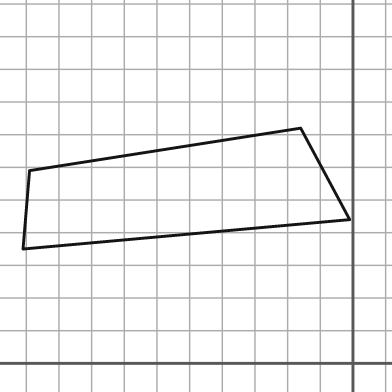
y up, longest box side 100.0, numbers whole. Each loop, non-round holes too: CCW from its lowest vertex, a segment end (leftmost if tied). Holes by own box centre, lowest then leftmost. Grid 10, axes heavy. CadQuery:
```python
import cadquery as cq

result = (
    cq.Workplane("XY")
    .moveTo(-101.0, 35.0)
    .lineTo(-1.0, 44.0)
    .lineTo(-16.0, 72.0)
    .lineTo(-99.0, 59.0)
    .close()
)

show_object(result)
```